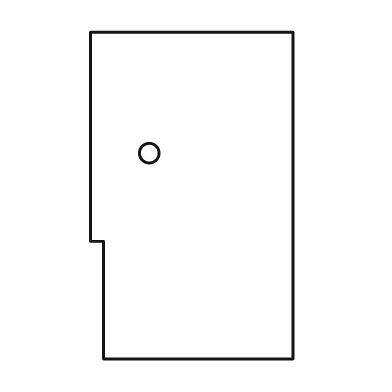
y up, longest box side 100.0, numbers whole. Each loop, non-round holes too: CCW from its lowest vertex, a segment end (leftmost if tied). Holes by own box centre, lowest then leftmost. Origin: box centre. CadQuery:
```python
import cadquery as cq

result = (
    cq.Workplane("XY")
    .moveTo(-27.0, -50.0)
    .lineTo(31.0, -50.0)
    .lineTo(31.0, 50.0)
    .lineTo(-31.0, 50.0)
    .lineTo(-31.0, -14.0)
    .lineTo(-27.0, -14.0)
    .close()
    .moveTo(-13.0, 13.0)
    .circle(3.0)
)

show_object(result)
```